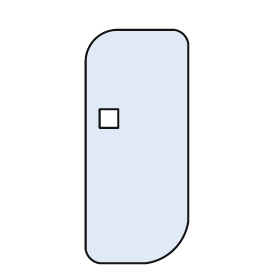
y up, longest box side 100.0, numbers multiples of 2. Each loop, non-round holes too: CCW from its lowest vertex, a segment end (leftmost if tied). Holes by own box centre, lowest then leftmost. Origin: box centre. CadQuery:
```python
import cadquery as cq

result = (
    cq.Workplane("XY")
    .moveTo(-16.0, -50.0)
    .lineTo(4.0, -50.0)
    .threePointArc((16.0, -44.0), (22.0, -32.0))
    .lineTo(22.0, 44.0)
    .threePointArc((20.0, 48.0), (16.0, 50.0))
    .lineTo(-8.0, 50.0)
    .threePointArc((-18.0, 46.0), (-22.0, 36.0))
    .lineTo(-22.0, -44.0)
    .threePointArc((-20.0, -48.0), (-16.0, -50.0))
    .close()
    .moveTo(-16.0, 8.0)
    .lineTo(-8.0, 8.0)
    .lineTo(-8.0, 16.0)
    .lineTo(-16.0, 16.0)
    .close()
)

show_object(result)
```